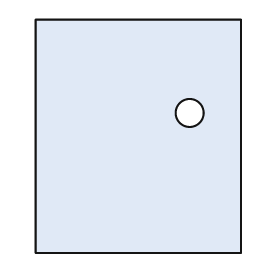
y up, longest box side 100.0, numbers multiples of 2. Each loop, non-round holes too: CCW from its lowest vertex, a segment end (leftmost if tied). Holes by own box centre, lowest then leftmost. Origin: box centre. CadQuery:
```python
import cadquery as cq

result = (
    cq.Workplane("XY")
    .moveTo(-44.0, -50.0)
    .lineTo(44.0, -50.0)
    .lineTo(44.0, 50.0)
    .lineTo(-44.0, 50.0)
    .close()
    .moveTo(22.0, 10.0)
    .circle(6.0)
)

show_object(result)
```